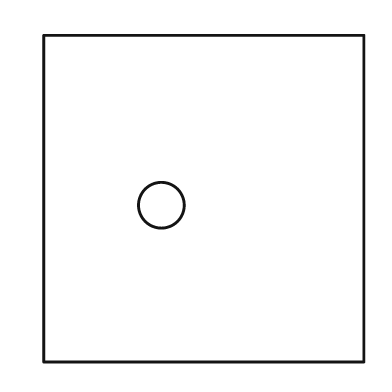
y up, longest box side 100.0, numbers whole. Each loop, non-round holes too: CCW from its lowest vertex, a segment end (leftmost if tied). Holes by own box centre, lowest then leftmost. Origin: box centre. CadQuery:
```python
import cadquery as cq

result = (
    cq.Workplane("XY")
    .moveTo(-49.0, -50.0)
    .lineTo(49.0, -50.0)
    .lineTo(49.0, 50.0)
    .lineTo(-49.0, 50.0)
    .close()
    .moveTo(-13.0, -2.0)
    .circle(7.0)
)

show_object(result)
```